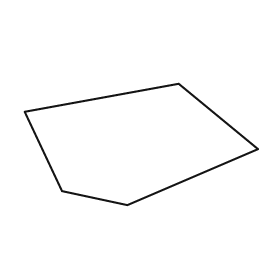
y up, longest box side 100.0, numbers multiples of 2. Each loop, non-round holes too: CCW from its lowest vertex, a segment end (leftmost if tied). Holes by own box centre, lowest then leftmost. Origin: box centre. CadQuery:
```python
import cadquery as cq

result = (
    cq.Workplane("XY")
    .moveTo(-6.0, -26.0)
    .lineTo(50.0, -2.0)
    .lineTo(16.0, 26.0)
    .lineTo(-50.0, 14.0)
    .lineTo(-34.0, -20.0)
    .close()
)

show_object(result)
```